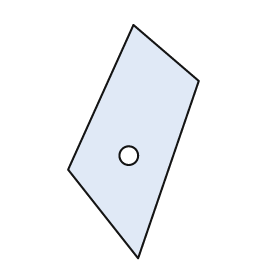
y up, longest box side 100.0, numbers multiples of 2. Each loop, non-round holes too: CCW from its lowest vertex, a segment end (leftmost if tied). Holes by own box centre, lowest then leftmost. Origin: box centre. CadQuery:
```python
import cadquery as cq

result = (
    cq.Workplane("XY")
    .moveTo(2.0, -50.0)
    .lineTo(28.0, 26.0)
    .lineTo(0.0, 50.0)
    .lineTo(-28.0, -12.0)
    .close()
    .moveTo(-2.0, -6.0)
    .circle(4.0)
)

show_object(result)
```